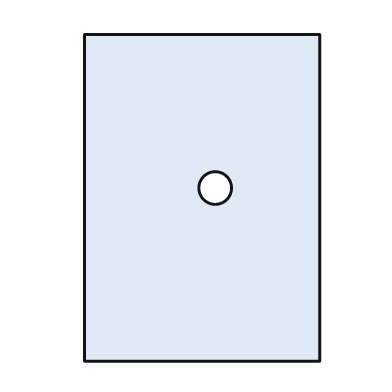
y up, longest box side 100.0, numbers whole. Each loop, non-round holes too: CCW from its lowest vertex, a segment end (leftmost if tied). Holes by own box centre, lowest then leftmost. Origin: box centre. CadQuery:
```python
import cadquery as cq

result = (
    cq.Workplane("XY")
    .moveTo(-36.0, -50.0)
    .lineTo(36.0, -50.0)
    .lineTo(36.0, 50.0)
    .lineTo(-36.0, 50.0)
    .close()
    .moveTo(4.0, 3.0)
    .circle(5.0)
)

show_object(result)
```